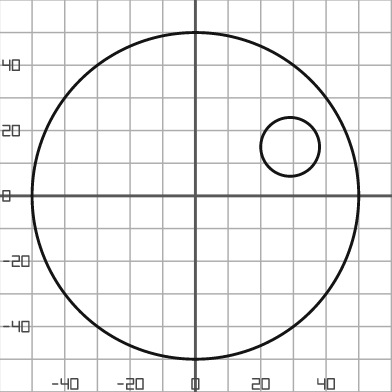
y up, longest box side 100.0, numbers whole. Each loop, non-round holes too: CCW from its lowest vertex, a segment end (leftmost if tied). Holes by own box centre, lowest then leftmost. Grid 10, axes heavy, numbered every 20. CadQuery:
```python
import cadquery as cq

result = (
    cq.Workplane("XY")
    .moveTo(0.0, 0.0)
    .circle(50.0)
    .moveTo(29.0, 15.0)
    .circle(9.0)
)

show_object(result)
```